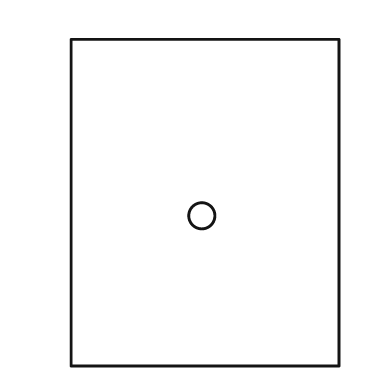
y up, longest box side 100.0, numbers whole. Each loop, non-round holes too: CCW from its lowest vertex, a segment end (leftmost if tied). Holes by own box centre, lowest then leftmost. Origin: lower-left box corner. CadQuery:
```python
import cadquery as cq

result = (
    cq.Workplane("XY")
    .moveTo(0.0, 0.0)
    .lineTo(82.0, 0.0)
    .lineTo(82.0, 100.0)
    .lineTo(0.0, 100.0)
    .close()
    .moveTo(40.0, 46.0)
    .circle(4.0)
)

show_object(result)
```